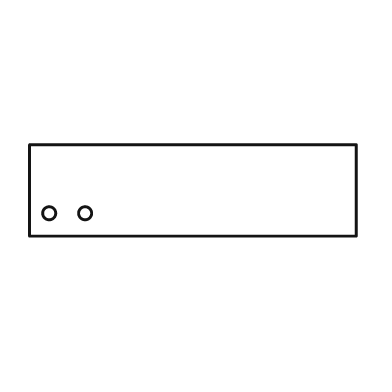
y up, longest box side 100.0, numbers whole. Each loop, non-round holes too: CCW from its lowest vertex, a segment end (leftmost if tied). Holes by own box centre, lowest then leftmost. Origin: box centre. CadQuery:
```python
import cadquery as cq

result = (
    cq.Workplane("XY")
    .moveTo(-50.0, -14.0)
    .lineTo(50.0, -14.0)
    .lineTo(50.0, 14.0)
    .lineTo(-50.0, 14.0)
    .close()
    .moveTo(-44.0, -7.0)
    .circle(2.0)
    .moveTo(-33.0, -7.0)
    .circle(2.0)
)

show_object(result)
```